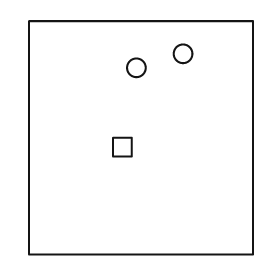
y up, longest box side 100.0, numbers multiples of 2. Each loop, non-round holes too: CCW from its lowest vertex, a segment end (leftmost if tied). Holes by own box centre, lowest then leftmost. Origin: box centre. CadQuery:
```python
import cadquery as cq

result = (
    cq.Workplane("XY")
    .moveTo(-48.0, -50.0)
    .lineTo(48.0, -50.0)
    .lineTo(48.0, 50.0)
    .lineTo(-48.0, 50.0)
    .close()
    .moveTo(-12.0, -8.0)
    .lineTo(-4.0, -8.0)
    .lineTo(-4.0, 0.0)
    .lineTo(-12.0, 0.0)
    .close()
    .moveTo(-2.0, 30.0)
    .circle(4.0)
    .moveTo(18.0, 36.0)
    .circle(4.0)
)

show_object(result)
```